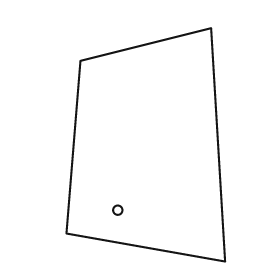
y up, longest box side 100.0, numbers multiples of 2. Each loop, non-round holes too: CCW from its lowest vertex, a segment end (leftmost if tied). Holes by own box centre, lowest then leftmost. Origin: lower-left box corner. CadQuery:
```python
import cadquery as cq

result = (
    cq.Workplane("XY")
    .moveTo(68.0, 0.0)
    .lineTo(62.0, 100.0)
    .lineTo(6.0, 86.0)
    .lineTo(0.0, 12.0)
    .close()
    .moveTo(22.0, 22.0)
    .circle(2.0)
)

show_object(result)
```